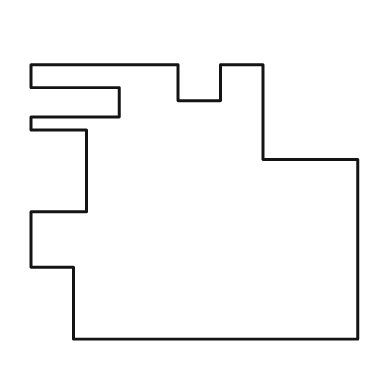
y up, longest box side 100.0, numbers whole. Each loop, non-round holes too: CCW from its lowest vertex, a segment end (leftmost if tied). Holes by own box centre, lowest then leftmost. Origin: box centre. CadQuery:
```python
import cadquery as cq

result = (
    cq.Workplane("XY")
    .moveTo(-37.0, -42.0)
    .lineTo(50.0, -42.0)
    .lineTo(50.0, 13.0)
    .lineTo(21.0, 13.0)
    .lineTo(21.0, 42.0)
    .lineTo(8.0, 42.0)
    .lineTo(8.0, 31.0)
    .lineTo(-5.0, 31.0)
    .lineTo(-5.0, 42.0)
    .lineTo(-50.0, 42.0)
    .lineTo(-50.0, 35.0)
    .lineTo(-23.0, 35.0)
    .lineTo(-23.0, 26.0)
    .lineTo(-50.0, 26.0)
    .lineTo(-50.0, 22.0)
    .lineTo(-33.0, 22.0)
    .lineTo(-33.0, -3.0)
    .lineTo(-50.0, -3.0)
    .lineTo(-50.0, -20.0)
    .lineTo(-37.0, -20.0)
    .close()
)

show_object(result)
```